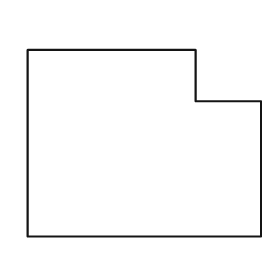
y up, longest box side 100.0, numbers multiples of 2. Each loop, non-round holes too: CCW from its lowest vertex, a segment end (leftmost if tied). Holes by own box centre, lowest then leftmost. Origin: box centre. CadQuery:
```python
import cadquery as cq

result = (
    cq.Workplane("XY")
    .moveTo(-50.0, -40.0)
    .lineTo(50.0, -40.0)
    .lineTo(50.0, 18.0)
    .lineTo(22.0, 18.0)
    .lineTo(22.0, 40.0)
    .lineTo(-50.0, 40.0)
    .close()
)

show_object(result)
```